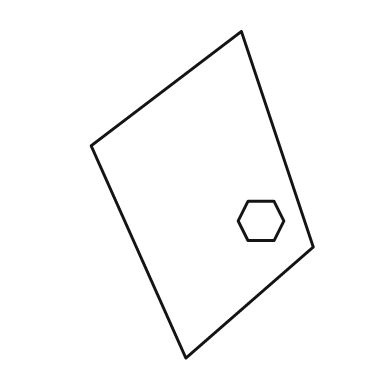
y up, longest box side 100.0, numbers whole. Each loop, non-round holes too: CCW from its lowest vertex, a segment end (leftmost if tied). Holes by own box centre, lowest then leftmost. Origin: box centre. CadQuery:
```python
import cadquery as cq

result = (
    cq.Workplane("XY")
    .moveTo(-5.0, -50.0)
    .lineTo(34.0, -16.0)
    .lineTo(12.0, 50.0)
    .lineTo(-34.0, 15.0)
    .close()
    .moveTo(14.0, -14.0)
    .lineTo(22.0, -14.0)
    .lineTo(25.0, -8.0)
    .lineTo(22.0, -2.0)
    .lineTo(14.0, -2.0)
    .lineTo(11.0, -8.0)
    .close()
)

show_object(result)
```